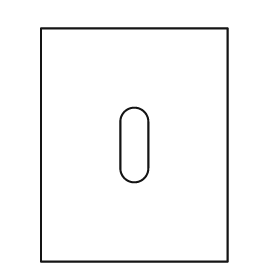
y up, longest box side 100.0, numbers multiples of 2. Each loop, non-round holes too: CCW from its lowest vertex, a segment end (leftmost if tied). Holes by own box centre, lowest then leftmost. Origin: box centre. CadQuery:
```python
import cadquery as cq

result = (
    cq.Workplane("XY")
    .moveTo(-40.0, -50.0)
    .lineTo(40.0, -50.0)
    .lineTo(40.0, 50.0)
    .lineTo(-40.0, 50.0)
    .close()
    .moveTo(-6.0, -10.0)
    .threePointArc((0.0, -16.0), (6.0, -10.0))
    .lineTo(6.0, 10.0)
    .threePointArc((0.0, 16.0), (-6.0, 10.0))
    .close()
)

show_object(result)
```